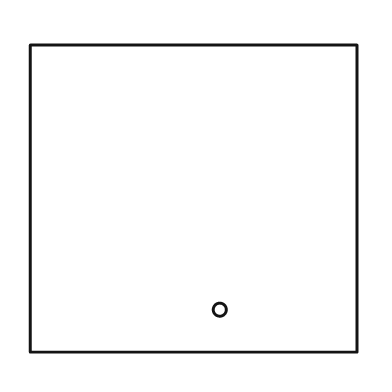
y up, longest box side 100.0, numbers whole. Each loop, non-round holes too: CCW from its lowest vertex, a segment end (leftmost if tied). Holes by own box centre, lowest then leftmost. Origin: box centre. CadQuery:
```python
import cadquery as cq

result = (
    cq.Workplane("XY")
    .moveTo(-50.0, -47.0)
    .lineTo(50.0, -47.0)
    .lineTo(50.0, 47.0)
    .lineTo(-50.0, 47.0)
    .close()
    .moveTo(8.0, -34.0)
    .circle(2.0)
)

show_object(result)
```